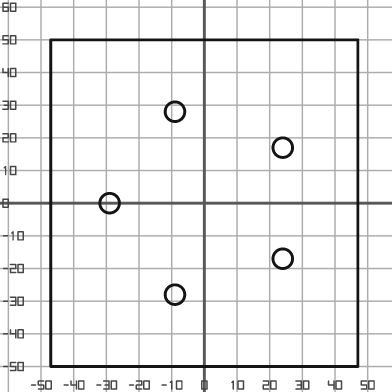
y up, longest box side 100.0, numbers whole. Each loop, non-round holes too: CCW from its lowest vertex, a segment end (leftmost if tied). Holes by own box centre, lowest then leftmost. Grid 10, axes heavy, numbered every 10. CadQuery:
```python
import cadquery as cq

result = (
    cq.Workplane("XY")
    .moveTo(-47.0, -50.0)
    .lineTo(47.0, -50.0)
    .lineTo(47.0, 50.0)
    .lineTo(-47.0, 50.0)
    .close()
    .moveTo(-9.0, -28.0)
    .circle(3.0)
    .moveTo(24.0, -17.0)
    .circle(3.0)
    .moveTo(-29.0, 0.0)
    .circle(3.0)
    .moveTo(24.0, 17.0)
    .circle(3.0)
    .moveTo(-9.0, 28.0)
    .circle(3.0)
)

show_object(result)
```